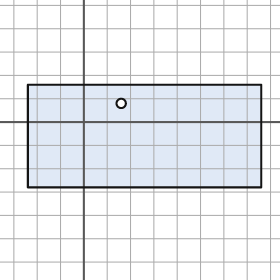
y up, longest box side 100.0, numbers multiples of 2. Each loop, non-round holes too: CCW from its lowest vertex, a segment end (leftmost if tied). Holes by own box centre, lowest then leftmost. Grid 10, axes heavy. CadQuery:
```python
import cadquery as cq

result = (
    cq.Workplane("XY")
    .moveTo(-24.0, -28.0)
    .lineTo(76.0, -28.0)
    .lineTo(76.0, 16.0)
    .lineTo(-24.0, 16.0)
    .close()
    .moveTo(16.0, 8.0)
    .circle(2.0)
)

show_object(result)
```